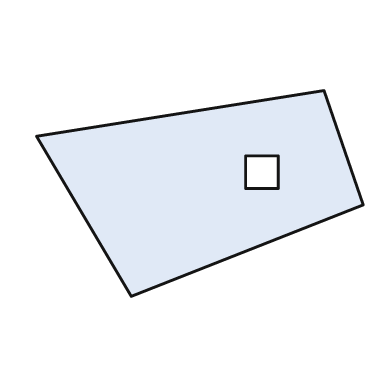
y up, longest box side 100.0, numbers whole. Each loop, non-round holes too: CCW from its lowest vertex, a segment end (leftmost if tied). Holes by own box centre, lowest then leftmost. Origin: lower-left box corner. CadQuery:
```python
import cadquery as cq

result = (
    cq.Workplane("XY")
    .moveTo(29.0, 0.0)
    .lineTo(100.0, 28.0)
    .lineTo(88.0, 63.0)
    .lineTo(0.0, 49.0)
    .close()
    .moveTo(64.0, 33.0)
    .lineTo(74.0, 33.0)
    .lineTo(74.0, 43.0)
    .lineTo(64.0, 43.0)
    .close()
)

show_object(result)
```